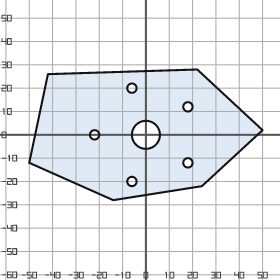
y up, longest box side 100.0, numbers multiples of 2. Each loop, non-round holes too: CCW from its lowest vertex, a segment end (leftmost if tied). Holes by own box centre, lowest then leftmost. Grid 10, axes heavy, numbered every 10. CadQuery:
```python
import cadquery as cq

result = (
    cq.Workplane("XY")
    .moveTo(-14.0, -28.0)
    .lineTo(24.0, -22.0)
    .lineTo(50.0, 2.0)
    .lineTo(22.0, 28.0)
    .lineTo(-42.0, 26.0)
    .lineTo(-50.0, -12.0)
    .close()
    .moveTo(-6.0, -20.0)
    .circle(2.0)
    .moveTo(18.0, -12.0)
    .circle(2.0)
    .moveTo(-22.0, 0.0)
    .circle(2.0)
    .moveTo(0.0, 0.0)
    .circle(6.0)
    .moveTo(18.0, 12.0)
    .circle(2.0)
    .moveTo(-6.0, 20.0)
    .circle(2.0)
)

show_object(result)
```